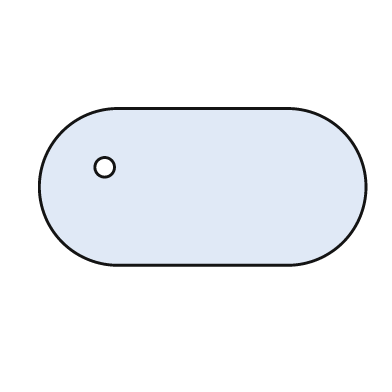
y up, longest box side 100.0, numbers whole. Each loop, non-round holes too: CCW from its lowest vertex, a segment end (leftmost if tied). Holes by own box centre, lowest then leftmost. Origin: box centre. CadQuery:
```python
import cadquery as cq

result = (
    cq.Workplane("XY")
    .moveTo(-26.0, -24.0)
    .lineTo(26.0, -24.0)
    .threePointArc((50.0, 0.0), (26.0, 24.0))
    .lineTo(-26.0, 24.0)
    .threePointArc((-50.0, 0.0), (-26.0, -24.0))
    .close()
    .moveTo(-30.0, 6.0)
    .circle(3.0)
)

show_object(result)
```